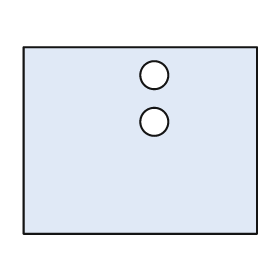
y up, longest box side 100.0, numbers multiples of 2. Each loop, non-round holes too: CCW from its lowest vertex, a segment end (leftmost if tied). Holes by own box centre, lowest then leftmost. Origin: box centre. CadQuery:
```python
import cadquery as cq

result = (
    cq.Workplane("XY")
    .moveTo(-50.0, -40.0)
    .lineTo(50.0, -40.0)
    .lineTo(50.0, 40.0)
    .lineTo(-50.0, 40.0)
    .close()
    .moveTo(6.0, 8.0)
    .circle(6.0)
    .moveTo(6.0, 28.0)
    .circle(6.0)
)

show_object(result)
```